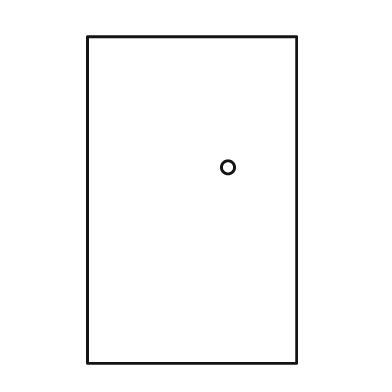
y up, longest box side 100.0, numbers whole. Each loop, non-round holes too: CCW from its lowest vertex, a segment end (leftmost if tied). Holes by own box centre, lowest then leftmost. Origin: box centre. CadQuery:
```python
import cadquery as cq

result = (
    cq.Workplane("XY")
    .moveTo(-32.0, -50.0)
    .lineTo(32.0, -50.0)
    .lineTo(32.0, 50.0)
    .lineTo(-32.0, 50.0)
    .close()
    .moveTo(11.0, 10.0)
    .circle(2.0)
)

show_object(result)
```